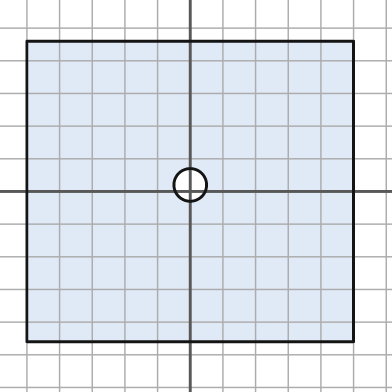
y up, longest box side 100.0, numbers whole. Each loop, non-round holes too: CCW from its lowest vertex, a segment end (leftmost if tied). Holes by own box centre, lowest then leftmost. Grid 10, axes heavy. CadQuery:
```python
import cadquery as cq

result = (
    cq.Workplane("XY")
    .moveTo(-50.0, -46.0)
    .lineTo(50.0, -46.0)
    .lineTo(50.0, 46.0)
    .lineTo(-50.0, 46.0)
    .close()
    .moveTo(0.0, 2.0)
    .circle(5.0)
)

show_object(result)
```